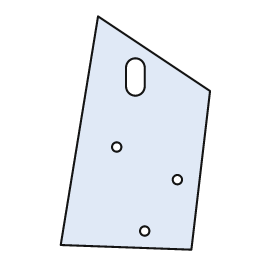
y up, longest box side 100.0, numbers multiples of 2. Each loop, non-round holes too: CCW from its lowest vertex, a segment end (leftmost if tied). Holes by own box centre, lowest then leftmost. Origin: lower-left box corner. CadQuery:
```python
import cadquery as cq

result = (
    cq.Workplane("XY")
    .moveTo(56.0, 0.0)
    .lineTo(64.0, 68.0)
    .lineTo(16.0, 100.0)
    .lineTo(0.0, 2.0)
    .close()
    .moveTo(36.0, 8.0)
    .circle(2.0)
    .moveTo(50.0, 30.0)
    .circle(2.0)
    .moveTo(24.0, 44.0)
    .circle(2.0)
    .moveTo(28.0, 70.0)
    .threePointArc((32.0, 66.0), (36.0, 70.0))
    .lineTo(36.0, 78.0)
    .threePointArc((32.0, 82.0), (28.0, 78.0))
    .close()
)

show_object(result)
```